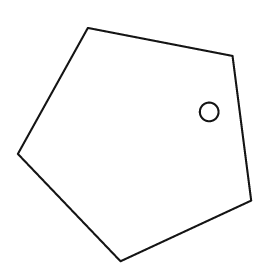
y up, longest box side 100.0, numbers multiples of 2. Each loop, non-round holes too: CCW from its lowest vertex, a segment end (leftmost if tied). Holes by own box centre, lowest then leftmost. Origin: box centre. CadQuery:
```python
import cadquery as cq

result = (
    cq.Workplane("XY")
    .moveTo(-6.0, -50.0)
    .lineTo(50.0, -24.0)
    .lineTo(42.0, 38.0)
    .lineTo(-20.0, 50.0)
    .lineTo(-50.0, -4.0)
    .close()
    .moveTo(32.0, 14.0)
    .circle(4.0)
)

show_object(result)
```